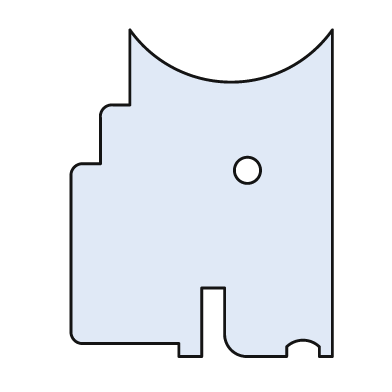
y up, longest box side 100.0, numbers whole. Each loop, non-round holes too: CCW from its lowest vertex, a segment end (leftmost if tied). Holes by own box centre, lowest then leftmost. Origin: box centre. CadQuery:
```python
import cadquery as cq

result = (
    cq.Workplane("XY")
    .moveTo(-7.0, -50.0)
    .lineTo(0.0, -50.0)
    .lineTo(0.0, -29.0)
    .lineTo(7.0, -29.0)
    .lineTo(7.0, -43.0)
    .threePointArc((9.0, -48.0), (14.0, -50.0))
    .lineTo(26.0, -50.0)
    .lineTo(26.0, -47.0)
    .threePointArc((31.0, -45.0), (36.0, -47.0))
    .lineTo(36.0, -50.0)
    .lineTo(40.0, -50.0)
    .lineTo(40.0, 50.0)
    .threePointArc((9.0, 34.0), (-22.0, 50.0))
    .lineTo(-22.0, 27.0)
    .lineTo(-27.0, 27.0)
    .threePointArc((-30.0, 26.0), (-31.0, 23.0))
    .lineTo(-31.0, 9.0)
    .lineTo(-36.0, 9.0)
    .threePointArc((-39.0, 8.0), (-40.0, 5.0))
    .lineTo(-40.0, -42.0)
    .threePointArc((-39.0, -45.0), (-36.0, -46.0))
    .lineTo(-7.0, -46.0)
    .close()
    .moveTo(14.0, 7.0)
    .circle(4.0)
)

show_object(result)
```